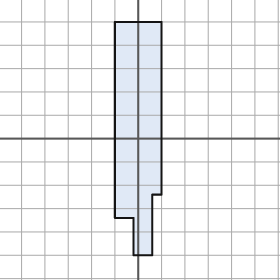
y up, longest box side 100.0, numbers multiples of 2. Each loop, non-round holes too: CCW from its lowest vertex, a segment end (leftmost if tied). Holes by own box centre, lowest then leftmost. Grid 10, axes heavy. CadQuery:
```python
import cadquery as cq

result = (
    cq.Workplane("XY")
    .moveTo(-2.0, -50.0)
    .lineTo(6.0, -50.0)
    .lineTo(6.0, -24.0)
    .lineTo(10.0, -24.0)
    .lineTo(10.0, 50.0)
    .lineTo(-10.0, 50.0)
    .lineTo(-10.0, -34.0)
    .lineTo(-2.0, -34.0)
    .close()
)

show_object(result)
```